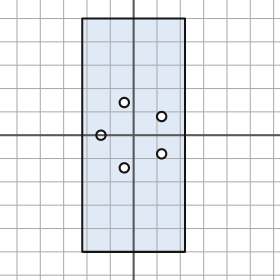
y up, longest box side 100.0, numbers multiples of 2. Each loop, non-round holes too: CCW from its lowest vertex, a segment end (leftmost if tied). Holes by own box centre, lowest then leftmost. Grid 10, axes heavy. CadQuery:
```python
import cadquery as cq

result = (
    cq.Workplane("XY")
    .moveTo(-22.0, -50.0)
    .lineTo(22.0, -50.0)
    .lineTo(22.0, 50.0)
    .lineTo(-22.0, 50.0)
    .close()
    .moveTo(-4.0, -14.0)
    .circle(2.0)
    .moveTo(12.0, -8.0)
    .circle(2.0)
    .moveTo(-14.0, 0.0)
    .circle(2.0)
    .moveTo(12.0, 8.0)
    .circle(2.0)
    .moveTo(-4.0, 14.0)
    .circle(2.0)
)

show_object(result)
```